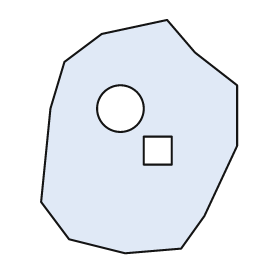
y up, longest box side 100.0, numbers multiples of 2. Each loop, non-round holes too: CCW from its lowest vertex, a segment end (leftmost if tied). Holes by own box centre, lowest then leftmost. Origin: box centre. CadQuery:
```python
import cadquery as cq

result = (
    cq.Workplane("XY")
    .moveTo(-6.0, -50.0)
    .lineTo(18.0, -48.0)
    .lineTo(28.0, -34.0)
    .lineTo(42.0, -4.0)
    .lineTo(42.0, 22.0)
    .lineTo(24.0, 36.0)
    .lineTo(12.0, 50.0)
    .lineTo(-16.0, 44.0)
    .lineTo(-32.0, 32.0)
    .lineTo(-38.0, 12.0)
    .lineTo(-42.0, -28.0)
    .lineTo(-30.0, -44.0)
    .close()
    .moveTo(2.0, -12.0)
    .lineTo(14.0, -12.0)
    .lineTo(14.0, 0.0)
    .lineTo(2.0, 0.0)
    .close()
    .moveTo(-8.0, 12.0)
    .circle(10.0)
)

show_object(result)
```